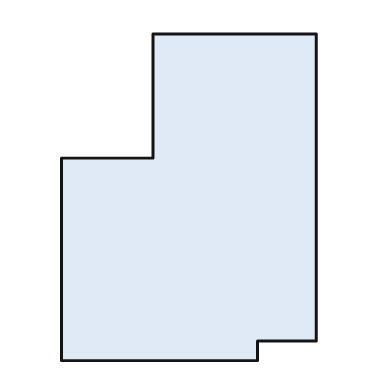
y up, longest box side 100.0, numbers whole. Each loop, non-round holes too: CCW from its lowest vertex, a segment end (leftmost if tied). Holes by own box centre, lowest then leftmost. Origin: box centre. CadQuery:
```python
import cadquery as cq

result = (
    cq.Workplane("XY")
    .moveTo(-39.0, -50.0)
    .lineTo(21.0, -50.0)
    .lineTo(21.0, -44.0)
    .lineTo(39.0, -44.0)
    .lineTo(39.0, 50.0)
    .lineTo(-11.0, 50.0)
    .lineTo(-11.0, 12.0)
    .lineTo(-39.0, 12.0)
    .close()
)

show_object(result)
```